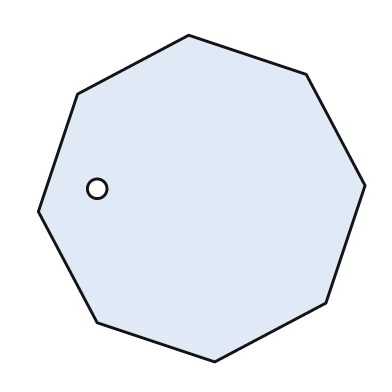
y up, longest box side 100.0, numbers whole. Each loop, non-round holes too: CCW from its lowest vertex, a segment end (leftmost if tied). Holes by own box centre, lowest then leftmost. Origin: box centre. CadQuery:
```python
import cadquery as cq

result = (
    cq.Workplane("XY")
    .moveTo(4.0, -50.0)
    .lineTo(38.0, -32.0)
    .lineTo(50.0, 4.0)
    .lineTo(32.0, 38.0)
    .lineTo(-4.0, 50.0)
    .lineTo(-38.0, 32.0)
    .lineTo(-50.0, -4.0)
    .lineTo(-32.0, -38.0)
    .close()
    .moveTo(-32.0, 3.0)
    .circle(3.0)
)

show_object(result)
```